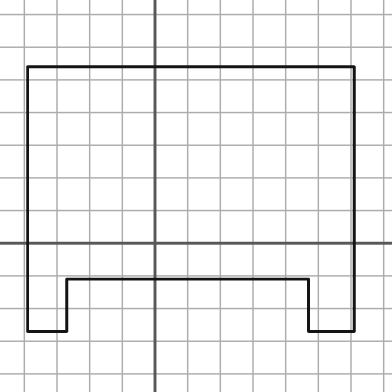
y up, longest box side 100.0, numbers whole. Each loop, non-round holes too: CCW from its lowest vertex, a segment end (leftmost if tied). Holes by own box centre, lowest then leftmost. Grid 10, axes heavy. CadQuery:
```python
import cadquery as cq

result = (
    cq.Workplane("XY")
    .moveTo(-39.0, -27.0)
    .lineTo(-27.0, -27.0)
    .lineTo(-27.0, -11.0)
    .lineTo(47.0, -11.0)
    .lineTo(47.0, -27.0)
    .lineTo(61.0, -27.0)
    .lineTo(61.0, 54.0)
    .lineTo(-39.0, 54.0)
    .close()
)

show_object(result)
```